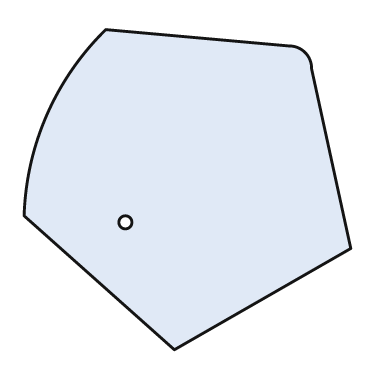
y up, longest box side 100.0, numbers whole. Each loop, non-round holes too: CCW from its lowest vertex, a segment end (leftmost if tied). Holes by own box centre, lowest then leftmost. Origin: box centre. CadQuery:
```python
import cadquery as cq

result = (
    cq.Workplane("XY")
    .moveTo(-4.0, -49.0)
    .lineTo(50.0, -18.0)
    .lineTo(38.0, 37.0)
    .threePointArc((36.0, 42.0), (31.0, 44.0))
    .lineTo(-25.0, 49.0)
    .threePointArc((-43.0, 23.0), (-50.0, -8.0))
    .close()
    .moveTo(-19.0, -10.0)
    .circle(2.0)
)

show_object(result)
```